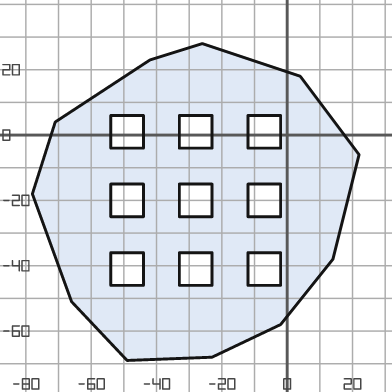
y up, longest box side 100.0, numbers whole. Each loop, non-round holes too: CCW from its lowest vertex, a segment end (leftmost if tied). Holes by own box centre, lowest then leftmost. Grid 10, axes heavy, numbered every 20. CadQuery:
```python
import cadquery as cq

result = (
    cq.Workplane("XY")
    .moveTo(-49.0, -69.0)
    .lineTo(-23.0, -68.0)
    .lineTo(-2.0, -58.0)
    .lineTo(14.0, -38.0)
    .lineTo(22.0, -6.0)
    .lineTo(4.0, 18.0)
    .lineTo(-26.0, 28.0)
    .lineTo(-42.0, 23.0)
    .lineTo(-71.0, 4.0)
    .lineTo(-78.0, -18.0)
    .lineTo(-66.0, -51.0)
    .close()
    .moveTo(-54.0, -46.0)
    .lineTo(-44.0, -46.0)
    .lineTo(-44.0, -36.0)
    .lineTo(-54.0, -36.0)
    .close()
    .moveTo(-33.0, -46.0)
    .lineTo(-23.0, -46.0)
    .lineTo(-23.0, -36.0)
    .lineTo(-33.0, -36.0)
    .close()
    .moveTo(-12.0, -46.0)
    .lineTo(-2.0, -46.0)
    .lineTo(-2.0, -36.0)
    .lineTo(-12.0, -36.0)
    .close()
    .moveTo(-54.0, -25.0)
    .lineTo(-44.0, -25.0)
    .lineTo(-44.0, -15.0)
    .lineTo(-54.0, -15.0)
    .close()
    .moveTo(-33.0, -25.0)
    .lineTo(-23.0, -25.0)
    .lineTo(-23.0, -15.0)
    .lineTo(-33.0, -15.0)
    .close()
    .moveTo(-12.0, -25.0)
    .lineTo(-2.0, -25.0)
    .lineTo(-2.0, -15.0)
    .lineTo(-12.0, -15.0)
    .close()
    .moveTo(-54.0, -4.0)
    .lineTo(-44.0, -4.0)
    .lineTo(-44.0, 6.0)
    .lineTo(-54.0, 6.0)
    .close()
    .moveTo(-33.0, -4.0)
    .lineTo(-23.0, -4.0)
    .lineTo(-23.0, 6.0)
    .lineTo(-33.0, 6.0)
    .close()
    .moveTo(-12.0, -4.0)
    .lineTo(-2.0, -4.0)
    .lineTo(-2.0, 6.0)
    .lineTo(-12.0, 6.0)
    .close()
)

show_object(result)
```